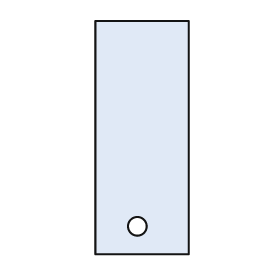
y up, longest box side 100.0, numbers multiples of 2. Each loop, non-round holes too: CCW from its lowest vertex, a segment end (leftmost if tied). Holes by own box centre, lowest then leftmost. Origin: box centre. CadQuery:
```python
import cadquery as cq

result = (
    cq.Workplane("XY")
    .moveTo(-20.0, -50.0)
    .lineTo(20.0, -50.0)
    .lineTo(20.0, 50.0)
    .lineTo(-20.0, 50.0)
    .close()
    .moveTo(-2.0, -38.0)
    .circle(4.0)
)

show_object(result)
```